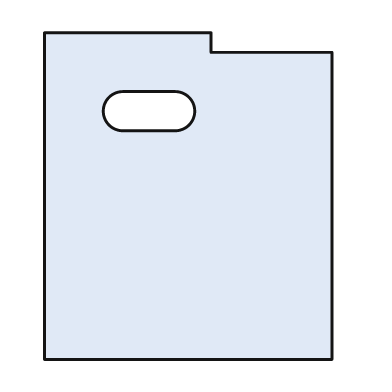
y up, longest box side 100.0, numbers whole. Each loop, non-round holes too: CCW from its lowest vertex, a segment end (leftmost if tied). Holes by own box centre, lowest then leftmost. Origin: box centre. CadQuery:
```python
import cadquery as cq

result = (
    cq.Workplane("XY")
    .moveTo(-44.0, -50.0)
    .lineTo(44.0, -50.0)
    .lineTo(44.0, 44.0)
    .lineTo(7.0, 44.0)
    .lineTo(7.0, 50.0)
    .lineTo(-44.0, 50.0)
    .close()
    .moveTo(-20.0, 20.0)
    .lineTo(-4.0, 20.0)
    .threePointArc((2.0, 26.0), (-4.0, 32.0))
    .lineTo(-20.0, 32.0)
    .threePointArc((-26.0, 26.0), (-20.0, 20.0))
    .close()
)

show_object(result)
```